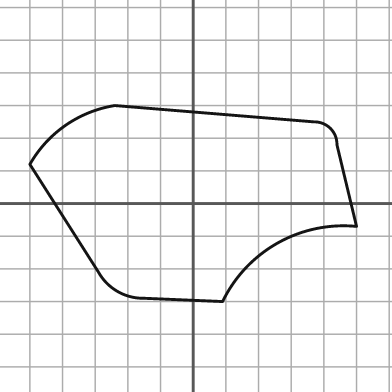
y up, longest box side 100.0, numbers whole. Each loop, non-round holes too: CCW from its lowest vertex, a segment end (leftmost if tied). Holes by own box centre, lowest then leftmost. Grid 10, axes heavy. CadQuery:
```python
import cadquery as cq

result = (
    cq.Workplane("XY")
    .moveTo(9.0, -30.0)
    .threePointArc((26.0, -12.0), (50.0, -7.0))
    .lineTo(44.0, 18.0)
    .threePointArc((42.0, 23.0), (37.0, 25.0))
    .lineTo(-24.0, 30.0)
    .threePointArc((-39.0, 24.0), (-50.0, 12.0))
    .lineTo(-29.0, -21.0)
    .threePointArc((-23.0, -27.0), (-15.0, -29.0))
    .close()
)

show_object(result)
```